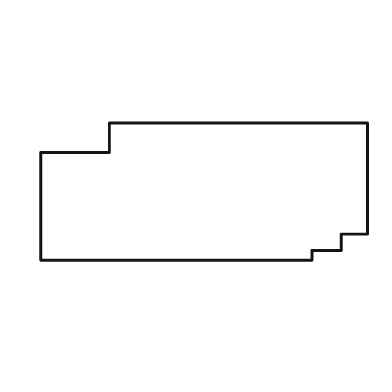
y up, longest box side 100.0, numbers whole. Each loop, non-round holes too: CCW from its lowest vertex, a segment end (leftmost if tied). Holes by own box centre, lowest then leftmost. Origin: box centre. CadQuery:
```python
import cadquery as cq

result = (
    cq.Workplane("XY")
    .moveTo(-50.0, -21.0)
    .lineTo(33.0, -21.0)
    .lineTo(33.0, -18.0)
    .lineTo(42.0, -18.0)
    .lineTo(42.0, -13.0)
    .lineTo(50.0, -13.0)
    .lineTo(50.0, 21.0)
    .lineTo(-29.0, 21.0)
    .lineTo(-29.0, 12.0)
    .lineTo(-50.0, 12.0)
    .close()
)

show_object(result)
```